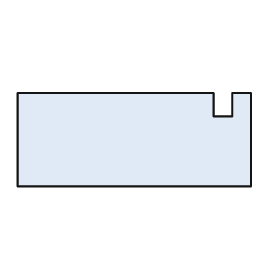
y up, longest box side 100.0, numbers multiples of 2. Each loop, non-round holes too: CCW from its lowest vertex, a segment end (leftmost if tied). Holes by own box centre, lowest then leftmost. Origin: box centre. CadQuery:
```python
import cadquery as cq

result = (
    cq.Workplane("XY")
    .moveTo(-50.0, -20.0)
    .lineTo(50.0, -20.0)
    .lineTo(50.0, 20.0)
    .lineTo(42.0, 20.0)
    .lineTo(42.0, 10.0)
    .lineTo(34.0, 10.0)
    .lineTo(34.0, 20.0)
    .lineTo(-50.0, 20.0)
    .close()
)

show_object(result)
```